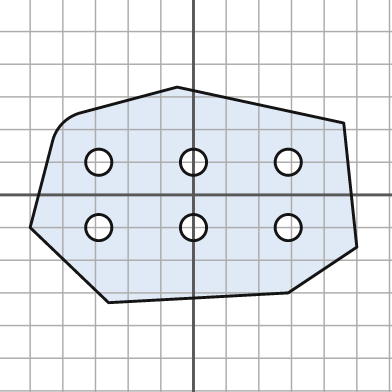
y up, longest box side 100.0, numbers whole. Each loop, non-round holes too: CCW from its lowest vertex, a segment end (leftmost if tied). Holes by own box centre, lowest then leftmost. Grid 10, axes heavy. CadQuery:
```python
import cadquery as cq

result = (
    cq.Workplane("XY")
    .moveTo(-26.0, -33.0)
    .lineTo(29.0, -30.0)
    .lineTo(50.0, -16.0)
    .lineTo(46.0, 22.0)
    .lineTo(-5.0, 33.0)
    .lineTo(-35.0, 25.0)
    .threePointArc((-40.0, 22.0), (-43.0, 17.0))
    .lineTo(-50.0, -10.0)
    .close()
    .moveTo(-29.0, -10.0)
    .circle(4.0)
    .moveTo(0.0, -10.0)
    .circle(4.0)
    .moveTo(29.0, -10.0)
    .circle(4.0)
    .moveTo(-29.0, 10.0)
    .circle(4.0)
    .moveTo(0.0, 10.0)
    .circle(4.0)
    .moveTo(29.0, 10.0)
    .circle(4.0)
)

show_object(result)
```